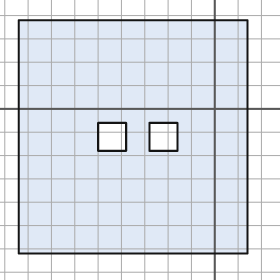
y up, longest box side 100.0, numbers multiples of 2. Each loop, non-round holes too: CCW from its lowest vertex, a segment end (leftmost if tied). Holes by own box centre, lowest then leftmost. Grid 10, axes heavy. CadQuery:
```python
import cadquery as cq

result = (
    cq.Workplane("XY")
    .moveTo(-84.0, -62.0)
    .lineTo(14.0, -62.0)
    .lineTo(14.0, 38.0)
    .lineTo(-84.0, 38.0)
    .close()
    .moveTo(-50.0, -18.0)
    .lineTo(-38.0, -18.0)
    .lineTo(-38.0, -6.0)
    .lineTo(-50.0, -6.0)
    .close()
    .moveTo(-28.0, -18.0)
    .lineTo(-16.0, -18.0)
    .lineTo(-16.0, -6.0)
    .lineTo(-28.0, -6.0)
    .close()
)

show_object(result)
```